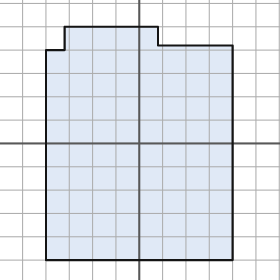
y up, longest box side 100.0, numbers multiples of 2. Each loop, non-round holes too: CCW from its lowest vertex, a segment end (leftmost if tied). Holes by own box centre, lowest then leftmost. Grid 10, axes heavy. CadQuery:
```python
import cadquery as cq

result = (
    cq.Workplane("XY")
    .moveTo(-40.0, -50.0)
    .lineTo(40.0, -50.0)
    .lineTo(40.0, 42.0)
    .lineTo(8.0, 42.0)
    .lineTo(8.0, 50.0)
    .lineTo(-32.0, 50.0)
    .lineTo(-32.0, 40.0)
    .lineTo(-40.0, 40.0)
    .close()
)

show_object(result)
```